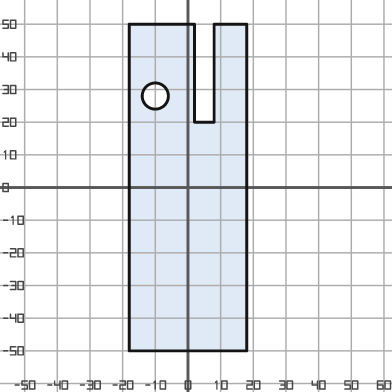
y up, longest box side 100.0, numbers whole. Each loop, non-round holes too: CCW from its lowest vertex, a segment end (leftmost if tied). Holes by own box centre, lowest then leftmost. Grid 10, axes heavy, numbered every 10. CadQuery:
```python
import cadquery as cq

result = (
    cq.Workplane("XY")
    .moveTo(-18.0, -50.0)
    .lineTo(18.0, -50.0)
    .lineTo(18.0, 50.0)
    .lineTo(8.0, 50.0)
    .lineTo(8.0, 20.0)
    .lineTo(2.0, 20.0)
    .lineTo(2.0, 50.0)
    .lineTo(-18.0, 50.0)
    .close()
    .moveTo(-10.0, 28.0)
    .circle(4.0)
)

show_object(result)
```